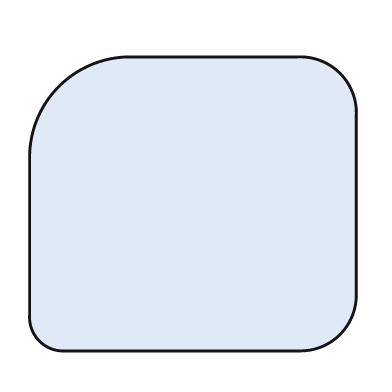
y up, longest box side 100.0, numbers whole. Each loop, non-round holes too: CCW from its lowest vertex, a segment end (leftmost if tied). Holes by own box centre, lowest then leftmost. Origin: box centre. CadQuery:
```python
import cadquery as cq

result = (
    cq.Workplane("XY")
    .moveTo(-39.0, -45.0)
    .lineTo(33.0, -45.0)
    .threePointArc((45.0, -40.0), (50.0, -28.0))
    .lineTo(50.0, 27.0)
    .threePointArc((45.0, 40.0), (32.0, 45.0))
    .lineTo(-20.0, 45.0)
    .threePointArc((-41.0, 36.0), (-50.0, 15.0))
    .lineTo(-50.0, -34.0)
    .threePointArc((-47.0, -42.0), (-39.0, -45.0))
    .close()
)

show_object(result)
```